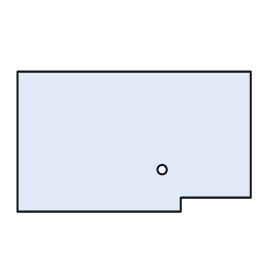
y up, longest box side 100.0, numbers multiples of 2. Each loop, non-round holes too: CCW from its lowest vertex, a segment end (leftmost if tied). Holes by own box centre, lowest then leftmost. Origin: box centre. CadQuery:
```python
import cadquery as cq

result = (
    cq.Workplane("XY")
    .moveTo(-50.0, -30.0)
    .lineTo(20.0, -30.0)
    .lineTo(20.0, -24.0)
    .lineTo(50.0, -24.0)
    .lineTo(50.0, 30.0)
    .lineTo(-50.0, 30.0)
    .close()
    .moveTo(12.0, -12.0)
    .circle(2.0)
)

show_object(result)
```